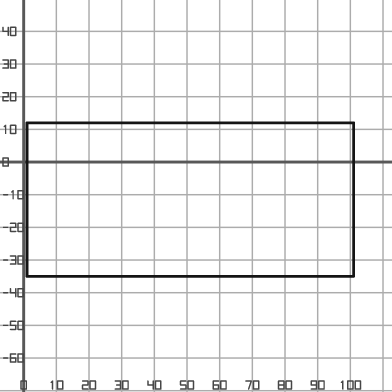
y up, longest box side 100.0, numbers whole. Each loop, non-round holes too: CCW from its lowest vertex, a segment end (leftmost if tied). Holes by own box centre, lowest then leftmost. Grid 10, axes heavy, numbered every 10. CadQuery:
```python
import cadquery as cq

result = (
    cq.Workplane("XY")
    .moveTo(1.0, -35.0)
    .lineTo(101.0, -35.0)
    .lineTo(101.0, 12.0)
    .lineTo(1.0, 12.0)
    .close()
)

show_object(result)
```